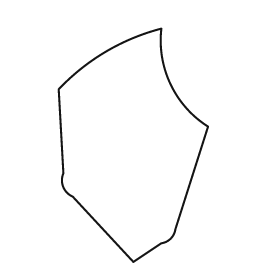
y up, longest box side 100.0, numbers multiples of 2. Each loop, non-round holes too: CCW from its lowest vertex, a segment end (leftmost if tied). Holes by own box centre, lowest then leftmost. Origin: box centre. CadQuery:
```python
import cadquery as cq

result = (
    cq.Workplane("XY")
    .moveTo(0.0, -50.0)
    .lineTo(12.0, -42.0)
    .threePointArc((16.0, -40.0), (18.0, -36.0))
    .lineTo(32.0, 8.0)
    .threePointArc((16.0, 26.0), (12.0, 50.0))
    .threePointArc((-12.0, 40.0), (-32.0, 24.0))
    .lineTo(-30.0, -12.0)
    .threePointArc((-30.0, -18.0), (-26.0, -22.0))
    .close()
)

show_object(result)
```